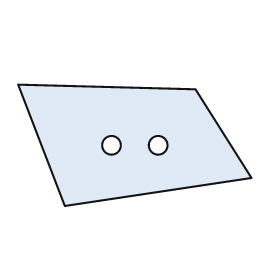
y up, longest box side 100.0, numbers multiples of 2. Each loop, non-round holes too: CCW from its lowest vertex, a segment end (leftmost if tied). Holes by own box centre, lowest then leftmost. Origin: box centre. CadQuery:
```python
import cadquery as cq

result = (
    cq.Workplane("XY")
    .moveTo(-30.0, -26.0)
    .lineTo(50.0, -14.0)
    .lineTo(26.0, 24.0)
    .lineTo(-50.0, 26.0)
    .close()
    .moveTo(-10.0, 0.0)
    .circle(4.0)
    .moveTo(10.0, 0.0)
    .circle(4.0)
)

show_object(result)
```